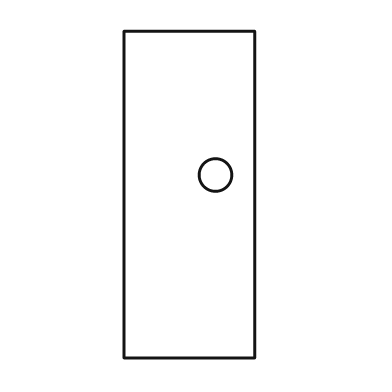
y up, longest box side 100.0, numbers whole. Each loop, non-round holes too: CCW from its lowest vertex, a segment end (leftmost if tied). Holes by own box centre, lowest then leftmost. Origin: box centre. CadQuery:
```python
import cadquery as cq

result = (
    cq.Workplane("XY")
    .moveTo(-20.0, -50.0)
    .lineTo(20.0, -50.0)
    .lineTo(20.0, 50.0)
    .lineTo(-20.0, 50.0)
    .close()
    .moveTo(8.0, 6.0)
    .circle(5.0)
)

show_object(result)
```